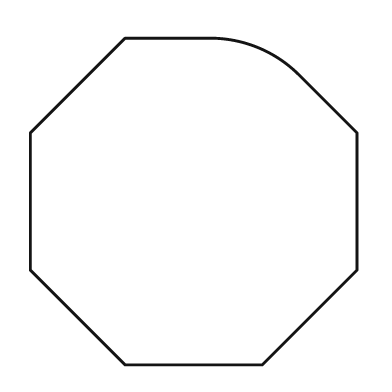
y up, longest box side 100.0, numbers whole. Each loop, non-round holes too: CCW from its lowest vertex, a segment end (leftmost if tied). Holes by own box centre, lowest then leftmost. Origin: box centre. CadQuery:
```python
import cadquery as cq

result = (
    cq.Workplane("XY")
    .moveTo(-21.0, -50.0)
    .lineTo(21.0, -50.0)
    .lineTo(50.0, -21.0)
    .lineTo(50.0, 21.0)
    .lineTo(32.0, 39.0)
    .threePointArc((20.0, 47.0), (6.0, 50.0))
    .lineTo(-21.0, 50.0)
    .lineTo(-50.0, 21.0)
    .lineTo(-50.0, -21.0)
    .close()
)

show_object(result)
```